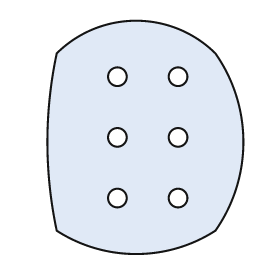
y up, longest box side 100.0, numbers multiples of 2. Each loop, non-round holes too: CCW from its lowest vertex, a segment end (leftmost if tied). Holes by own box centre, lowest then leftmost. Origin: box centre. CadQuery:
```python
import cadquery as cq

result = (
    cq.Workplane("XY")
    .moveTo(-38.0, -40.0)
    .threePointArc((-4.0, -50.0), (30.0, -40.0))
    .threePointArc((42.0, -2.0), (30.0, 36.0))
    .threePointArc((-4.0, 50.0), (-38.0, 36.0))
    .threePointArc((-42.0, -2.0), (-38.0, -40.0))
    .close()
    .moveTo(-12.0, -26.0)
    .circle(4.0)
    .moveTo(14.0, -26.0)
    .circle(4.0)
    .moveTo(-12.0, 0.0)
    .circle(4.0)
    .moveTo(14.0, 0.0)
    .circle(4.0)
    .moveTo(-12.0, 26.0)
    .circle(4.0)
    .moveTo(14.0, 26.0)
    .circle(4.0)
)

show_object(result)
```